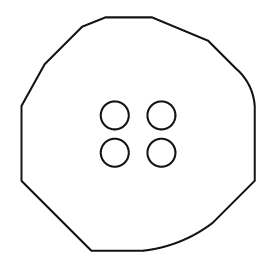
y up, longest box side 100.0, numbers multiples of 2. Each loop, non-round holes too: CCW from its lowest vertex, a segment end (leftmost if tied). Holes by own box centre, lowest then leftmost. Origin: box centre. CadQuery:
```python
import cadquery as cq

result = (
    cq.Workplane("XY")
    .moveTo(-20.0, -50.0)
    .lineTo(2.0, -50.0)
    .threePointArc((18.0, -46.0), (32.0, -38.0))
    .lineTo(50.0, -20.0)
    .lineTo(50.0, 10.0)
    .threePointArc((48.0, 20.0), (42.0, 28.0))
    .lineTo(30.0, 40.0)
    .lineTo(6.0, 50.0)
    .lineTo(-14.0, 50.0)
    .lineTo(-24.0, 46.0)
    .lineTo(-40.0, 30.0)
    .lineTo(-50.0, 12.0)
    .lineTo(-50.0, -20.0)
    .close()
    .moveTo(-10.0, -8.0)
    .circle(6.0)
    .moveTo(10.0, -8.0)
    .circle(6.0)
    .moveTo(-10.0, 8.0)
    .circle(6.0)
    .moveTo(10.0, 8.0)
    .circle(6.0)
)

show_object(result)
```